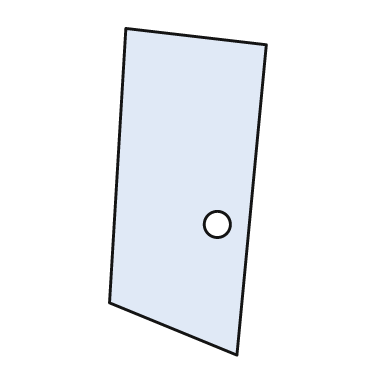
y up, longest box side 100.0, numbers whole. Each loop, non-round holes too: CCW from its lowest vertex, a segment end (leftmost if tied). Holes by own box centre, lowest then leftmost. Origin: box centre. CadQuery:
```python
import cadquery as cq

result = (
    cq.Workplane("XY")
    .moveTo(15.0, -50.0)
    .lineTo(24.0, 45.0)
    .lineTo(-19.0, 50.0)
    .lineTo(-24.0, -34.0)
    .close()
    .moveTo(9.0, -10.0)
    .circle(4.0)
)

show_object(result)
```